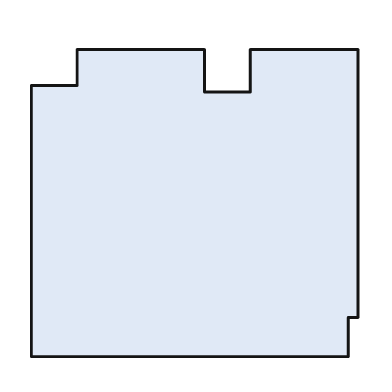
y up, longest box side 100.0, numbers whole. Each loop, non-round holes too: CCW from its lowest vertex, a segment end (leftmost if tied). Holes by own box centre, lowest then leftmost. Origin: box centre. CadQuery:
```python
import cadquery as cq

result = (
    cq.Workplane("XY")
    .moveTo(-50.0, -47.0)
    .lineTo(47.0, -47.0)
    .lineTo(47.0, -35.0)
    .lineTo(50.0, -35.0)
    .lineTo(50.0, 47.0)
    .lineTo(17.0, 47.0)
    .lineTo(17.0, 34.0)
    .lineTo(3.0, 34.0)
    .lineTo(3.0, 47.0)
    .lineTo(-36.0, 47.0)
    .lineTo(-36.0, 36.0)
    .lineTo(-50.0, 36.0)
    .close()
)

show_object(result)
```